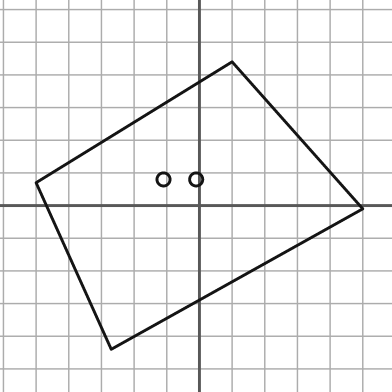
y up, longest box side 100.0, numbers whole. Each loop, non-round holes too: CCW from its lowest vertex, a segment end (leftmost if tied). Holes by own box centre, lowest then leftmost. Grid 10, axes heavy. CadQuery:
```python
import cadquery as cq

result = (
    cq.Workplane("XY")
    .moveTo(-27.0, -44.0)
    .lineTo(50.0, -1.0)
    .lineTo(10.0, 44.0)
    .lineTo(-50.0, 7.0)
    .close()
    .moveTo(-11.0, 8.0)
    .circle(2.0)
    .moveTo(-1.0, 8.0)
    .circle(2.0)
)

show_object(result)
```